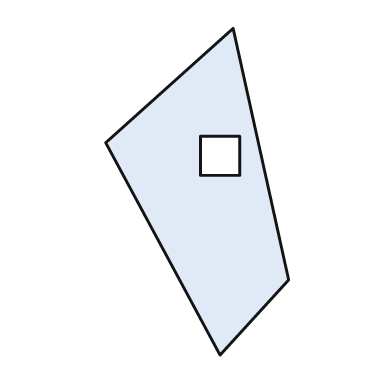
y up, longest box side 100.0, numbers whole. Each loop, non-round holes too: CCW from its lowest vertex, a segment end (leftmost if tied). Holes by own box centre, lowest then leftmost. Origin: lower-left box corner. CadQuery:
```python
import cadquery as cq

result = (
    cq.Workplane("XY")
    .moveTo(35.0, 0.0)
    .lineTo(56.0, 23.0)
    .lineTo(39.0, 100.0)
    .lineTo(0.0, 65.0)
    .close()
    .moveTo(29.0, 55.0)
    .lineTo(41.0, 55.0)
    .lineTo(41.0, 67.0)
    .lineTo(29.0, 67.0)
    .close()
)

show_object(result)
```